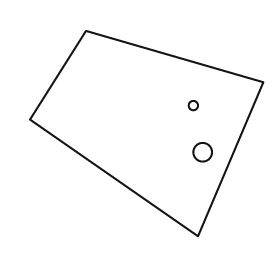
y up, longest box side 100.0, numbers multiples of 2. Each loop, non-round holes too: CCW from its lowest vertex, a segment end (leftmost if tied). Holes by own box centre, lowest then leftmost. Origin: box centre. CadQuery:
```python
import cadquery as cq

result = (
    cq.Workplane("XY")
    .moveTo(22.0, -44.0)
    .lineTo(50.0, 22.0)
    .lineTo(-26.0, 44.0)
    .lineTo(-50.0, 6.0)
    .close()
    .moveTo(24.0, -8.0)
    .circle(4.0)
    .moveTo(20.0, 12.0)
    .circle(2.0)
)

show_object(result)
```